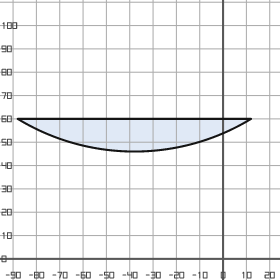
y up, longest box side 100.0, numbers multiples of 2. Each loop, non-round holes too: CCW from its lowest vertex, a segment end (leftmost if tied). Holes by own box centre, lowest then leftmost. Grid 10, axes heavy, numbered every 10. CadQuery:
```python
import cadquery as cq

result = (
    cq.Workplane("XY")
    .moveTo(-88.0, 60.0)
    .threePointArc((-38.0, 46.0), (12.0, 60.0))
    .close()
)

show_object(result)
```